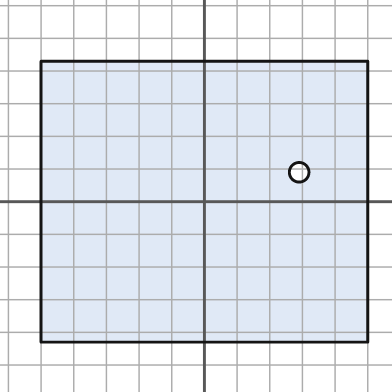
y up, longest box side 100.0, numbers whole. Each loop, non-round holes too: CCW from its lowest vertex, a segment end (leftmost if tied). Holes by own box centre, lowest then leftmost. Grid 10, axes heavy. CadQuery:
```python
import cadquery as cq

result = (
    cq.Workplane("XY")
    .moveTo(-50.0, -43.0)
    .lineTo(50.0, -43.0)
    .lineTo(50.0, 43.0)
    .lineTo(-50.0, 43.0)
    .close()
    .moveTo(29.0, 9.0)
    .circle(3.0)
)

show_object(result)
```